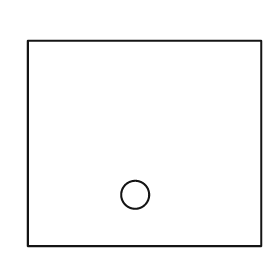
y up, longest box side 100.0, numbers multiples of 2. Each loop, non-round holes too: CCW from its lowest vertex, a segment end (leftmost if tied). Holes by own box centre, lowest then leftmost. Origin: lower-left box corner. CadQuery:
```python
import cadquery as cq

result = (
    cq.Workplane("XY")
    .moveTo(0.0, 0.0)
    .lineTo(100.0, 0.0)
    .lineTo(100.0, 88.0)
    .lineTo(0.0, 88.0)
    .close()
    .moveTo(46.0, 22.0)
    .circle(6.0)
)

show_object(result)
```